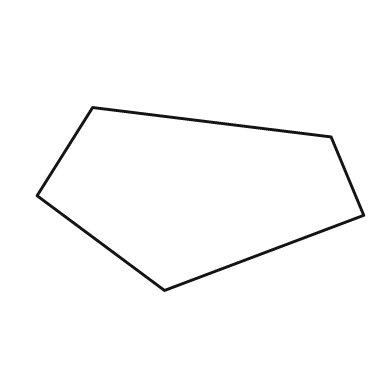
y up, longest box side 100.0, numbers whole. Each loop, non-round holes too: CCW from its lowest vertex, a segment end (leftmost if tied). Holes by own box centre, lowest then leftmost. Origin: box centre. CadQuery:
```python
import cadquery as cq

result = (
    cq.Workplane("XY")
    .moveTo(-11.0, -28.0)
    .lineTo(50.0, -5.0)
    .lineTo(40.0, 19.0)
    .lineTo(-33.0, 28.0)
    .lineTo(-50.0, 1.0)
    .close()
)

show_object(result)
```